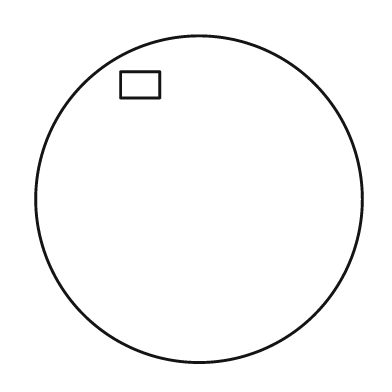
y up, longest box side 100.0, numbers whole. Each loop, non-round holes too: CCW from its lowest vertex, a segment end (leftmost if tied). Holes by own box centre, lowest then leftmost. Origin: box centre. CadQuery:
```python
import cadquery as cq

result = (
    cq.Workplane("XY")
    .moveTo(0.0, 0.0)
    .circle(50.0)
    .moveTo(-24.0, 31.0)
    .lineTo(-12.0, 31.0)
    .lineTo(-12.0, 39.0)
    .lineTo(-24.0, 39.0)
    .close()
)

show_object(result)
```